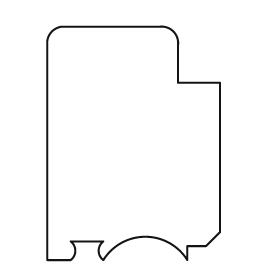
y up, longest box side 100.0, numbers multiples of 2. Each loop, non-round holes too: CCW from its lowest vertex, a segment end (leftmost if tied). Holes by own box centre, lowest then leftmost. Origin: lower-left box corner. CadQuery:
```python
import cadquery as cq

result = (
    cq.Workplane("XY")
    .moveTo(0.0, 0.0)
    .lineTo(10.0, 0.0)
    .threePointArc((12.0, 4.0), (10.0, 8.0))
    .lineTo(24.0, 8.0)
    .threePointArc((22.0, 4.0), (24.0, 0.0))
    .threePointArc((42.0, 10.0), (60.0, 0.0))
    .lineTo(60.0, 6.0)
    .lineTo(68.0, 6.0)
    .lineTo(74.0, 12.0)
    .lineTo(74.0, 76.0)
    .lineTo(56.0, 76.0)
    .lineTo(56.0, 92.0)
    .threePointArc((54.0, 98.0), (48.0, 100.0))
    .lineTo(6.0, 100.0)
    .threePointArc((2.0, 98.0), (0.0, 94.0))
    .close()
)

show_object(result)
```